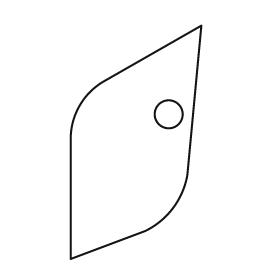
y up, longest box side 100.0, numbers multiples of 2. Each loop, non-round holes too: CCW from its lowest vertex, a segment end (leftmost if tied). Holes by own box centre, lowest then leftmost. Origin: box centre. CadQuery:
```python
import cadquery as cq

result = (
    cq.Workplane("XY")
    .moveTo(-28.0, -50.0)
    .lineTo(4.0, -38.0)
    .threePointArc((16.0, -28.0), (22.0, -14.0))
    .lineTo(28.0, 50.0)
    .lineTo(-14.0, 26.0)
    .threePointArc((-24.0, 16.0), (-28.0, 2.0))
    .close()
    .moveTo(14.0, 12.0)
    .circle(6.0)
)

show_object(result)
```